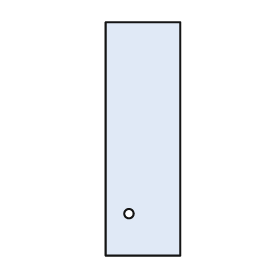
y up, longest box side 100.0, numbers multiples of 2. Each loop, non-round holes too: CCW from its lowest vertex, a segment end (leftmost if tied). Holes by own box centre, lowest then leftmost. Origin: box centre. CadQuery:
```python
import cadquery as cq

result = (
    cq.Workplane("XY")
    .moveTo(-16.0, -50.0)
    .lineTo(16.0, -50.0)
    .lineTo(16.0, 50.0)
    .lineTo(-16.0, 50.0)
    .close()
    .moveTo(-6.0, -32.0)
    .circle(2.0)
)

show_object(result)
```